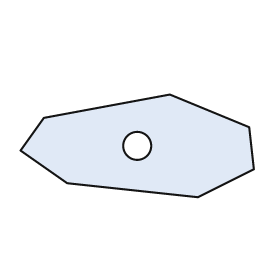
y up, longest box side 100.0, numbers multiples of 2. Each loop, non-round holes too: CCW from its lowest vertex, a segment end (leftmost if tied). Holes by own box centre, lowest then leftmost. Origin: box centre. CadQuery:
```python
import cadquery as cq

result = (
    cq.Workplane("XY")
    .moveTo(26.0, -22.0)
    .lineTo(50.0, -10.0)
    .lineTo(48.0, 8.0)
    .lineTo(14.0, 22.0)
    .lineTo(-40.0, 12.0)
    .lineTo(-50.0, -2.0)
    .lineTo(-30.0, -16.0)
    .close()
    .moveTo(0.0, 0.0)
    .circle(6.0)
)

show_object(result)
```